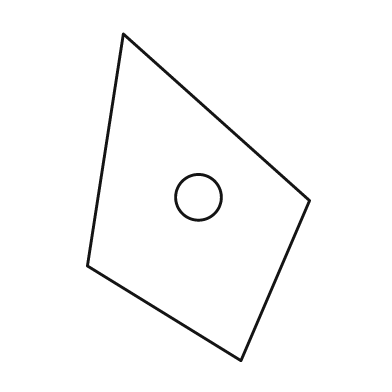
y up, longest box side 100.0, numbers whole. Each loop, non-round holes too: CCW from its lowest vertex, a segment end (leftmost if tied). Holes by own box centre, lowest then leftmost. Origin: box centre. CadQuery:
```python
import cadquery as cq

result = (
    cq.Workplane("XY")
    .moveTo(13.0, -50.0)
    .lineTo(34.0, -1.0)
    .lineTo(-23.0, 50.0)
    .lineTo(-34.0, -21.0)
    .close()
    .moveTo(0.0, 0.0)
    .circle(7.0)
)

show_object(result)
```